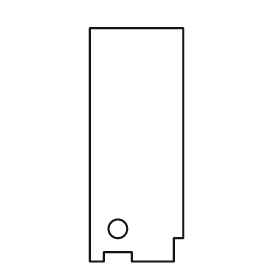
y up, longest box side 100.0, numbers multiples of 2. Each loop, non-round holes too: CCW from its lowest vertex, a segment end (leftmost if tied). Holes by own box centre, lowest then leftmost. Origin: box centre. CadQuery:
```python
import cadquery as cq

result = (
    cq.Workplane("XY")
    .moveTo(-20.0, -50.0)
    .lineTo(-14.0, -50.0)
    .lineTo(-14.0, -46.0)
    .lineTo(-2.0, -46.0)
    .lineTo(-2.0, -50.0)
    .lineTo(16.0, -50.0)
    .lineTo(16.0, -40.0)
    .lineTo(20.0, -40.0)
    .lineTo(20.0, 50.0)
    .lineTo(-20.0, 50.0)
    .close()
    .moveTo(-8.0, -36.0)
    .circle(4.0)
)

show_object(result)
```